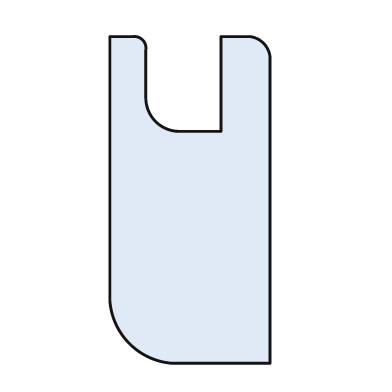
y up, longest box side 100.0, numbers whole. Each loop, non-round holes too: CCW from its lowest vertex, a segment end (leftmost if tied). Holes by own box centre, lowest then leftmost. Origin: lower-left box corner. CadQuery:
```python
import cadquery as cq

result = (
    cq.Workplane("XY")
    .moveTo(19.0, 0.0)
    .lineTo(49.0, 0.0)
    .lineTo(49.0, 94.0)
    .threePointArc((47.0, 98.0), (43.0, 100.0))
    .lineTo(34.0, 100.0)
    .lineTo(34.0, 71.0)
    .lineTo(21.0, 71.0)
    .threePointArc((14.0, 74.0), (11.0, 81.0))
    .lineTo(11.0, 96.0)
    .threePointArc((10.0, 99.0), (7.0, 100.0))
    .lineTo(0.0, 100.0)
    .lineTo(0.0, 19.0)
    .threePointArc((6.0, 6.0), (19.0, 0.0))
    .close()
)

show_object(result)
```